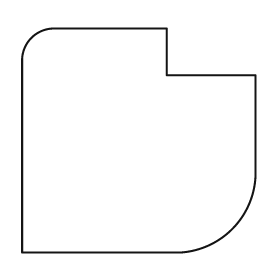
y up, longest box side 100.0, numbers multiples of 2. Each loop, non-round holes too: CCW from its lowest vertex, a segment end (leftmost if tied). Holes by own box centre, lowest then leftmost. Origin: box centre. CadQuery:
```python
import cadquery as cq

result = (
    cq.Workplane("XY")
    .moveTo(-50.0, -48.0)
    .lineTo(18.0, -48.0)
    .threePointArc((40.0, -38.0), (50.0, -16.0))
    .lineTo(50.0, 28.0)
    .lineTo(12.0, 28.0)
    .lineTo(12.0, 48.0)
    .lineTo(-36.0, 48.0)
    .threePointArc((-46.0, 44.0), (-50.0, 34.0))
    .close()
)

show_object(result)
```